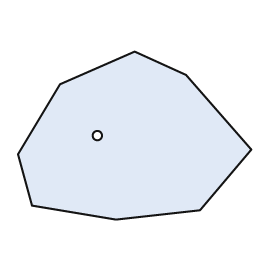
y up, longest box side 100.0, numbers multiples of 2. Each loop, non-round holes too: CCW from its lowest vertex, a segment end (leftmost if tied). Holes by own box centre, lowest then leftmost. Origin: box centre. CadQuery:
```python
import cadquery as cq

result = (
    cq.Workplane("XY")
    .moveTo(-8.0, -36.0)
    .lineTo(28.0, -32.0)
    .lineTo(50.0, -6.0)
    .lineTo(22.0, 26.0)
    .lineTo(0.0, 36.0)
    .lineTo(-32.0, 22.0)
    .lineTo(-50.0, -8.0)
    .lineTo(-44.0, -30.0)
    .close()
    .moveTo(-16.0, 0.0)
    .circle(2.0)
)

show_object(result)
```